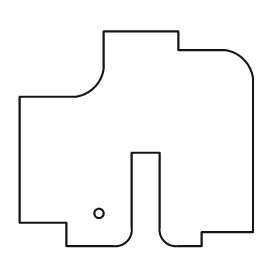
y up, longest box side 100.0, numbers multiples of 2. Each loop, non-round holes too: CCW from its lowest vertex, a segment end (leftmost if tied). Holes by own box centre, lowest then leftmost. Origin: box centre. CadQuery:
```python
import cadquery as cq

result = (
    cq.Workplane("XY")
    .moveTo(-30.0, -46.0)
    .lineTo(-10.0, -46.0)
    .threePointArc((-4.0, -44.0), (-2.0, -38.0))
    .lineTo(-2.0, -6.0)
    .lineTo(10.0, -6.0)
    .lineTo(10.0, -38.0)
    .threePointArc((12.0, -44.0), (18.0, -46.0))
    .lineTo(28.0, -46.0)
    .lineTo(28.0, -40.0)
    .lineTo(50.0, -40.0)
    .lineTo(50.0, 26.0)
    .threePointArc((46.0, 34.0), (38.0, 38.0))
    .lineTo(18.0, 38.0)
    .lineTo(18.0, 46.0)
    .lineTo(-14.0, 46.0)
    .lineTo(-14.0, 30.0)
    .threePointArc((-18.0, 22.0), (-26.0, 18.0))
    .lineTo(-50.0, 18.0)
    .lineTo(-50.0, -36.0)
    .lineTo(-30.0, -36.0)
    .close()
    .moveTo(-16.0, -32.0)
    .circle(2.0)
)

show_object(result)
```